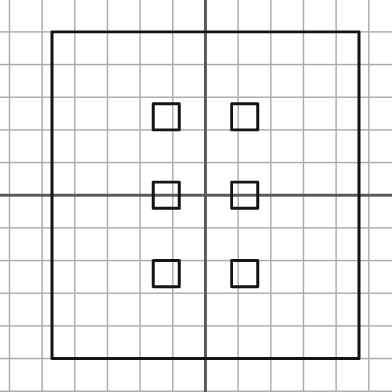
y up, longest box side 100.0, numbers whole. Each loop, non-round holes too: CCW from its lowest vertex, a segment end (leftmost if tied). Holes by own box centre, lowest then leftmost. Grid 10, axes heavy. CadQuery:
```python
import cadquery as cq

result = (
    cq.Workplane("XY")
    .moveTo(-47.0, -50.0)
    .lineTo(47.0, -50.0)
    .lineTo(47.0, 50.0)
    .lineTo(-47.0, 50.0)
    .close()
    .moveTo(-16.0, -28.0)
    .lineTo(-8.0, -28.0)
    .lineTo(-8.0, -20.0)
    .lineTo(-16.0, -20.0)
    .close()
    .moveTo(8.0, -28.0)
    .lineTo(16.0, -28.0)
    .lineTo(16.0, -20.0)
    .lineTo(8.0, -20.0)
    .close()
    .moveTo(-16.0, -4.0)
    .lineTo(-8.0, -4.0)
    .lineTo(-8.0, 4.0)
    .lineTo(-16.0, 4.0)
    .close()
    .moveTo(8.0, -4.0)
    .lineTo(16.0, -4.0)
    .lineTo(16.0, 4.0)
    .lineTo(8.0, 4.0)
    .close()
    .moveTo(-16.0, 20.0)
    .lineTo(-8.0, 20.0)
    .lineTo(-8.0, 28.0)
    .lineTo(-16.0, 28.0)
    .close()
    .moveTo(8.0, 20.0)
    .lineTo(16.0, 20.0)
    .lineTo(16.0, 28.0)
    .lineTo(8.0, 28.0)
    .close()
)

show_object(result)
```